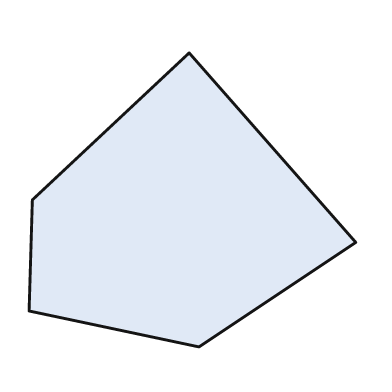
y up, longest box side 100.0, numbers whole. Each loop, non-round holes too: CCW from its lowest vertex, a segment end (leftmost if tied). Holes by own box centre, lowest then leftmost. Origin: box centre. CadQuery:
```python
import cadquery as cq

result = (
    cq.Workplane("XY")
    .moveTo(2.0, -45.0)
    .lineTo(50.0, -13.0)
    .lineTo(-1.0, 45.0)
    .lineTo(-49.0, 0.0)
    .lineTo(-50.0, -34.0)
    .close()
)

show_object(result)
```